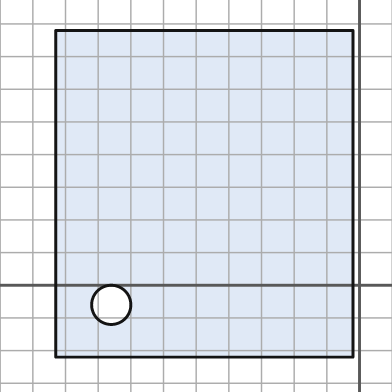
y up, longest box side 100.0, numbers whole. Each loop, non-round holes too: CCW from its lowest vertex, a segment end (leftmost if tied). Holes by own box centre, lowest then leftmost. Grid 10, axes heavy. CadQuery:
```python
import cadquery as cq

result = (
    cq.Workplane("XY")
    .moveTo(-93.0, -22.0)
    .lineTo(-2.0, -22.0)
    .lineTo(-2.0, 78.0)
    .lineTo(-93.0, 78.0)
    .close()
    .moveTo(-76.0, -6.0)
    .circle(6.0)
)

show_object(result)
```